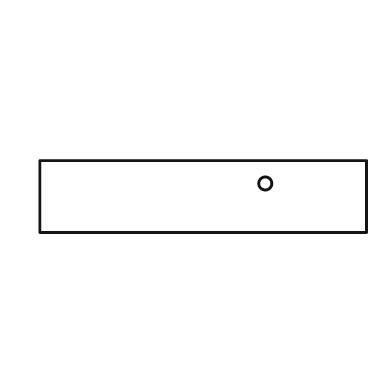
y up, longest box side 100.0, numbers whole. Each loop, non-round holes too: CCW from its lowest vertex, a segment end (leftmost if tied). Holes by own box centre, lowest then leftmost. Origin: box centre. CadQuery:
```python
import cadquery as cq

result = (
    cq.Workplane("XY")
    .moveTo(-50.0, -11.0)
    .lineTo(50.0, -11.0)
    .lineTo(50.0, 11.0)
    .lineTo(-50.0, 11.0)
    .close()
    .moveTo(19.0, 4.0)
    .circle(2.0)
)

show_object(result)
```